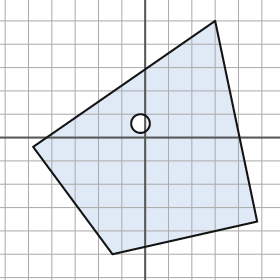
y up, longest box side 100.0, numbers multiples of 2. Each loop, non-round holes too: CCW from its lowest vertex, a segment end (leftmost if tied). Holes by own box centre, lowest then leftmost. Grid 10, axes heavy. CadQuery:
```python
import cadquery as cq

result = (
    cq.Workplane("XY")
    .moveTo(-14.0, -50.0)
    .lineTo(48.0, -36.0)
    .lineTo(30.0, 50.0)
    .lineTo(-48.0, -4.0)
    .close()
    .moveTo(-2.0, 6.0)
    .circle(4.0)
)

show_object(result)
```